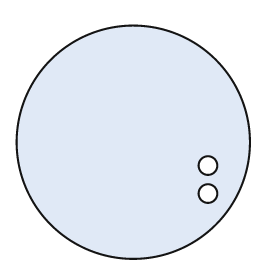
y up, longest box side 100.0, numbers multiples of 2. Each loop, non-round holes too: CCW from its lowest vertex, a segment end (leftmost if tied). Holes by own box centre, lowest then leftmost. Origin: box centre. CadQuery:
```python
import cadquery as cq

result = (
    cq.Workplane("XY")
    .moveTo(0.0, 0.0)
    .circle(50.0)
    .moveTo(32.0, -22.0)
    .circle(4.0)
    .moveTo(32.0, -10.0)
    .circle(4.0)
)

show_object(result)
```